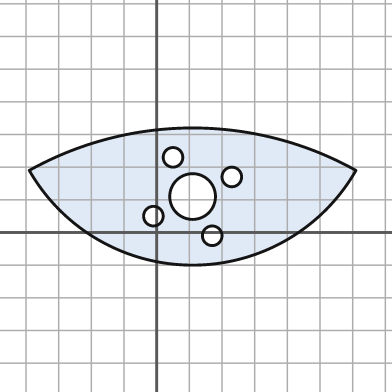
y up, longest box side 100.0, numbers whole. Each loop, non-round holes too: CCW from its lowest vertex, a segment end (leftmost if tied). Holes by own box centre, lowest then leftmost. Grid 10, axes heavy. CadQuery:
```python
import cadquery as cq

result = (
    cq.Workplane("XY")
    .moveTo(-39.0, 19.0)
    .threePointArc((11.0, -10.0), (61.0, 19.0))
    .threePointArc((11.0, 32.0), (-39.0, 19.0))
    .close()
    .moveTo(17.0, -1.0)
    .circle(3.0)
    .moveTo(-1.0, 5.0)
    .circle(3.0)
    .moveTo(11.0, 11.0)
    .circle(7.0)
    .moveTo(23.0, 17.0)
    .circle(3.0)
    .moveTo(5.0, 23.0)
    .circle(3.0)
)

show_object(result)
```